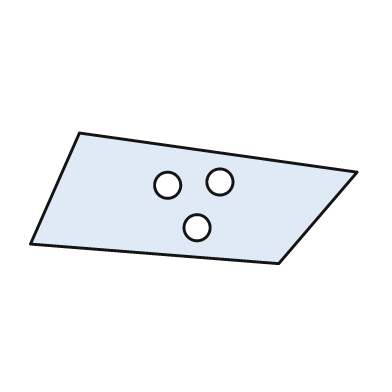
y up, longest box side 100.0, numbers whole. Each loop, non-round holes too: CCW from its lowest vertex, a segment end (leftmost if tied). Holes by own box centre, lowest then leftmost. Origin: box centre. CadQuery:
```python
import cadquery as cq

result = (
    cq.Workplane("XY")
    .moveTo(26.0, -20.0)
    .lineTo(50.0, 8.0)
    .lineTo(-35.0, 20.0)
    .lineTo(-50.0, -14.0)
    .close()
    .moveTo(1.0, -9.0)
    .circle(4.0)
    .moveTo(-8.0, 4.0)
    .circle(4.0)
    .moveTo(8.0, 5.0)
    .circle(4.0)
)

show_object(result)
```